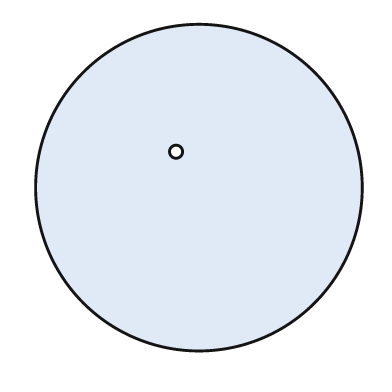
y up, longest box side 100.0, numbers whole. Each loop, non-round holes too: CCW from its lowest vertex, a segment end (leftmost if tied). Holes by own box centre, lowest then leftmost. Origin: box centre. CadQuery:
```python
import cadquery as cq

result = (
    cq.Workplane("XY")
    .moveTo(0.0, 0.0)
    .circle(50.0)
    .moveTo(-7.0, 11.0)
    .circle(2.0)
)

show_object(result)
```